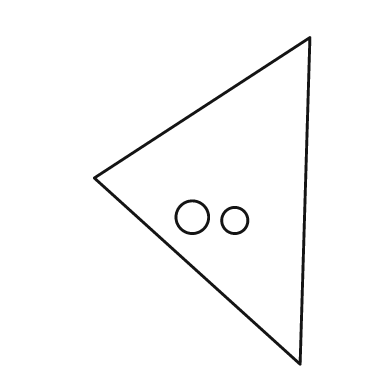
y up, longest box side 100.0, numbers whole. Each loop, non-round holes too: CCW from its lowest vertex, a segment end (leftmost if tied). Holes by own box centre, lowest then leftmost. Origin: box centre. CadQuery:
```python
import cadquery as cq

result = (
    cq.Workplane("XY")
    .moveTo(30.0, -50.0)
    .lineTo(33.0, 50.0)
    .lineTo(-33.0, 7.0)
    .close()
    .moveTo(10.0, -6.0)
    .circle(4.0)
    .moveTo(-3.0, -5.0)
    .circle(5.0)
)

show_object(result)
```